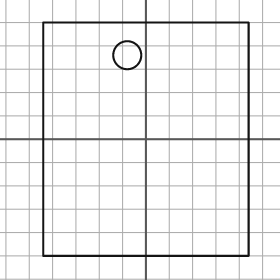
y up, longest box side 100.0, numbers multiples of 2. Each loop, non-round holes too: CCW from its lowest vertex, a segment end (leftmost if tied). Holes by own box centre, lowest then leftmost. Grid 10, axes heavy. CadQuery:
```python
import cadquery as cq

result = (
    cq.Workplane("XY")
    .moveTo(-44.0, -50.0)
    .lineTo(44.0, -50.0)
    .lineTo(44.0, 50.0)
    .lineTo(-44.0, 50.0)
    .close()
    .moveTo(-8.0, 36.0)
    .circle(6.0)
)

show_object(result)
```